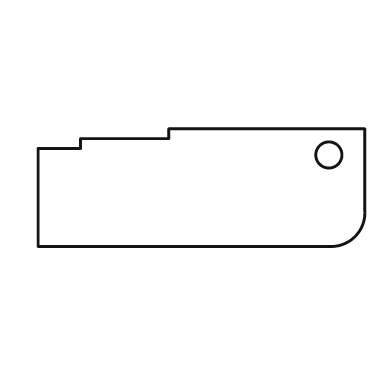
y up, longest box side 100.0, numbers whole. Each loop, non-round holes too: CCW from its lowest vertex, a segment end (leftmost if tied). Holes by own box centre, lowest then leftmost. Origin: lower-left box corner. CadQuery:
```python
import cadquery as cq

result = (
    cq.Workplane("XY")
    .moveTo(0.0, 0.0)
    .lineTo(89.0, 0.0)
    .threePointArc((97.0, 3.0), (100.0, 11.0))
    .lineTo(100.0, 36.0)
    .lineTo(40.0, 36.0)
    .lineTo(40.0, 33.0)
    .lineTo(13.0, 33.0)
    .lineTo(13.0, 30.0)
    .lineTo(0.0, 30.0)
    .close()
    .moveTo(89.0, 28.0)
    .circle(4.0)
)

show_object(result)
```